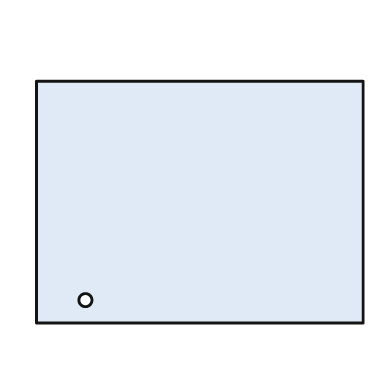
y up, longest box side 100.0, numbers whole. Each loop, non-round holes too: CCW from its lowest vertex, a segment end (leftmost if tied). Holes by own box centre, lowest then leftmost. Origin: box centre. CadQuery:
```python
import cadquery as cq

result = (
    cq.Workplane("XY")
    .moveTo(-50.0, -37.0)
    .lineTo(50.0, -37.0)
    .lineTo(50.0, 37.0)
    .lineTo(-50.0, 37.0)
    .close()
    .moveTo(-35.0, -30.0)
    .circle(2.0)
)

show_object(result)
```